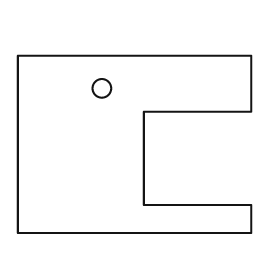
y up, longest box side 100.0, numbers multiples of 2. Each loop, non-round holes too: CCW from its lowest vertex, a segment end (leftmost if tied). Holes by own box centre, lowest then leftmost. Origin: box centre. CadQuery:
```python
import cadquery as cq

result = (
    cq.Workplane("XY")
    .moveTo(-50.0, -38.0)
    .lineTo(50.0, -38.0)
    .lineTo(50.0, -26.0)
    .lineTo(4.0, -26.0)
    .lineTo(4.0, 14.0)
    .lineTo(50.0, 14.0)
    .lineTo(50.0, 38.0)
    .lineTo(-50.0, 38.0)
    .close()
    .moveTo(-14.0, 24.0)
    .circle(4.0)
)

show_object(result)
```